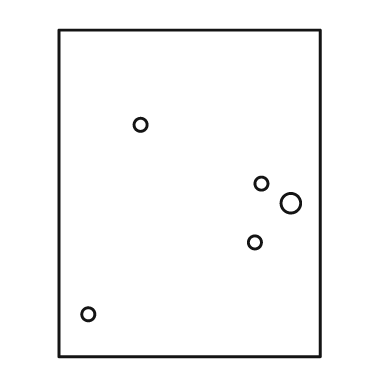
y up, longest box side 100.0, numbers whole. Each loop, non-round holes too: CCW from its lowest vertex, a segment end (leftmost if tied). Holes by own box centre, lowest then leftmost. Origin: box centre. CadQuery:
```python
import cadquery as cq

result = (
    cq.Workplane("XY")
    .moveTo(-40.0, -50.0)
    .lineTo(40.0, -50.0)
    .lineTo(40.0, 50.0)
    .lineTo(-40.0, 50.0)
    .close()
    .moveTo(-31.0, -37.0)
    .circle(2.0)
    .moveTo(20.0, -15.0)
    .circle(2.0)
    .moveTo(31.0, -3.0)
    .circle(3.0)
    .moveTo(22.0, 3.0)
    .circle(2.0)
    .moveTo(-15.0, 21.0)
    .circle(2.0)
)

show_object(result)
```